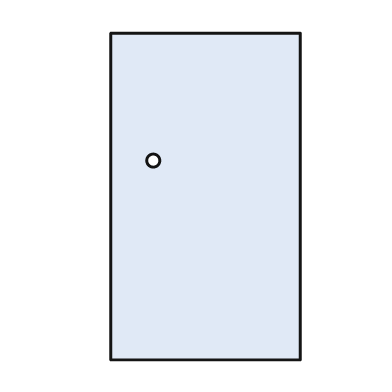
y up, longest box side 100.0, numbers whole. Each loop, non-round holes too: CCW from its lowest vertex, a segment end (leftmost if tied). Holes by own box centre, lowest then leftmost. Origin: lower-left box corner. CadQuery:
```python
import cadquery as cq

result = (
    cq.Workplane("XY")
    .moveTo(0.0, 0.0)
    .lineTo(58.0, 0.0)
    .lineTo(58.0, 100.0)
    .lineTo(0.0, 100.0)
    .close()
    .moveTo(13.0, 61.0)
    .circle(2.0)
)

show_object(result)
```